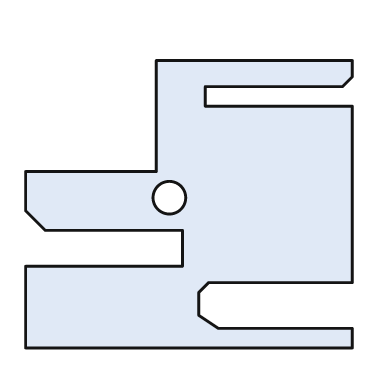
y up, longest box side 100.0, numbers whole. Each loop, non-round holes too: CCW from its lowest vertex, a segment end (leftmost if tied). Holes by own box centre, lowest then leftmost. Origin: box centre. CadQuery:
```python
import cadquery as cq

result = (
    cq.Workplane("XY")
    .moveTo(-50.0, -44.0)
    .lineTo(50.0, -44.0)
    .lineTo(50.0, -38.0)
    .lineTo(9.0, -38.0)
    .lineTo(3.0, -34.0)
    .lineTo(3.0, -27.0)
    .lineTo(6.0, -24.0)
    .lineTo(50.0, -24.0)
    .lineTo(50.0, 30.0)
    .lineTo(5.0, 30.0)
    .lineTo(5.0, 36.0)
    .lineTo(47.0, 36.0)
    .lineTo(50.0, 39.0)
    .lineTo(50.0, 44.0)
    .lineTo(-10.0, 44.0)
    .lineTo(-10.0, 10.0)
    .lineTo(-50.0, 10.0)
    .lineTo(-50.0, -2.0)
    .lineTo(-44.0, -8.0)
    .lineTo(-2.0, -8.0)
    .lineTo(-2.0, -19.0)
    .lineTo(-50.0, -19.0)
    .close()
    .moveTo(-6.0, 2.0)
    .circle(5.0)
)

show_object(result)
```